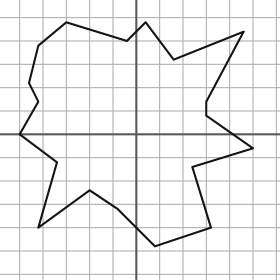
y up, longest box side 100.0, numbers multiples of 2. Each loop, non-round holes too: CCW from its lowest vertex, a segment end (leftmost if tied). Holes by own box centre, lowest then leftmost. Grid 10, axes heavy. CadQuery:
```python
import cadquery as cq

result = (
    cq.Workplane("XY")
    .moveTo(8.0, -48.0)
    .lineTo(32.0, -40.0)
    .lineTo(24.0, -14.0)
    .lineTo(50.0, -6.0)
    .lineTo(30.0, 8.0)
    .lineTo(30.0, 14.0)
    .lineTo(46.0, 44.0)
    .lineTo(16.0, 32.0)
    .lineTo(4.0, 48.0)
    .lineTo(-4.0, 40.0)
    .lineTo(-30.0, 48.0)
    .lineTo(-42.0, 38.0)
    .lineTo(-46.0, 22.0)
    .lineTo(-42.0, 14.0)
    .lineTo(-50.0, 0.0)
    .lineTo(-34.0, -12.0)
    .lineTo(-42.0, -40.0)
    .lineTo(-20.0, -24.0)
    .lineTo(-8.0, -32.0)
    .close()
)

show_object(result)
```